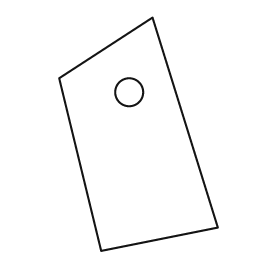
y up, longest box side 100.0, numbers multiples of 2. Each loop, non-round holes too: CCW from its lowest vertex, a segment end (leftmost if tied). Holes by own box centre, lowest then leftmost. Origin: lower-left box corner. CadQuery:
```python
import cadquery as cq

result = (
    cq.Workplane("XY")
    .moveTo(18.0, 0.0)
    .lineTo(68.0, 10.0)
    .lineTo(40.0, 100.0)
    .lineTo(0.0, 74.0)
    .close()
    .moveTo(30.0, 68.0)
    .circle(6.0)
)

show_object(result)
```